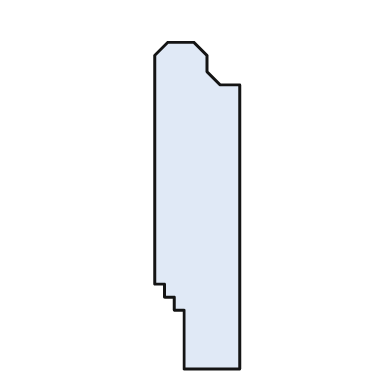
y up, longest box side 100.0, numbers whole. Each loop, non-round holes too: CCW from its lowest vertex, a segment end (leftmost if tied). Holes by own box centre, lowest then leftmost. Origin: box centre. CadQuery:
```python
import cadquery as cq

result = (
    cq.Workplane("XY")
    .moveTo(-4.0, -50.0)
    .lineTo(13.0, -50.0)
    .lineTo(13.0, 37.0)
    .lineTo(7.0, 37.0)
    .lineTo(3.0, 41.0)
    .lineTo(3.0, 46.0)
    .lineTo(-1.0, 50.0)
    .lineTo(-9.0, 50.0)
    .lineTo(-13.0, 46.0)
    .lineTo(-13.0, -24.0)
    .lineTo(-10.0, -24.0)
    .lineTo(-10.0, -28.0)
    .lineTo(-7.0, -28.0)
    .lineTo(-7.0, -32.0)
    .lineTo(-4.0, -32.0)
    .close()
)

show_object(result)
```